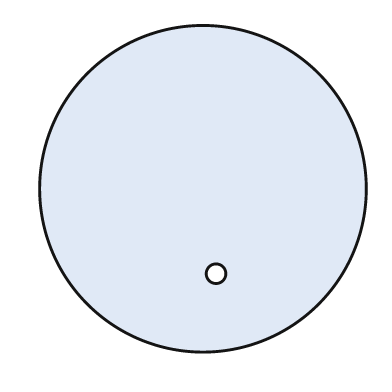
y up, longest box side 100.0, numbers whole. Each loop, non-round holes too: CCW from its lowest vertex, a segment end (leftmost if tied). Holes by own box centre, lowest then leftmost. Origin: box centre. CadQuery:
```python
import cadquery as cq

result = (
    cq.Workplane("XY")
    .moveTo(0.0, 0.0)
    .circle(50.0)
    .moveTo(4.0, -26.0)
    .circle(3.0)
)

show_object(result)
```